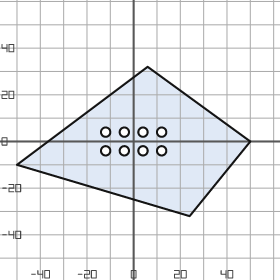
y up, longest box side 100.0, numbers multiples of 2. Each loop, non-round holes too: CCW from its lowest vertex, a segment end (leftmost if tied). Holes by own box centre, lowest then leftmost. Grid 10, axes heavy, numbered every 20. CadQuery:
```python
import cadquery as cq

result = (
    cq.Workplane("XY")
    .moveTo(24.0, -32.0)
    .lineTo(50.0, 0.0)
    .lineTo(6.0, 32.0)
    .lineTo(-50.0, -10.0)
    .close()
    .moveTo(-12.0, -4.0)
    .circle(2.0)
    .moveTo(-4.0, -4.0)
    .circle(2.0)
    .moveTo(4.0, -4.0)
    .circle(2.0)
    .moveTo(12.0, -4.0)
    .circle(2.0)
    .moveTo(-12.0, 4.0)
    .circle(2.0)
    .moveTo(-4.0, 4.0)
    .circle(2.0)
    .moveTo(4.0, 4.0)
    .circle(2.0)
    .moveTo(12.0, 4.0)
    .circle(2.0)
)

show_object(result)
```